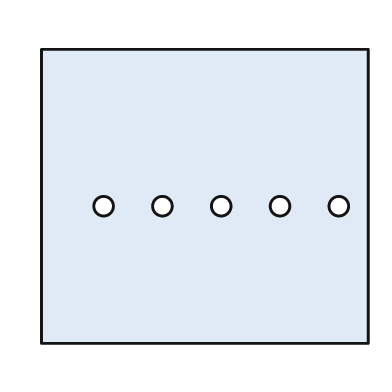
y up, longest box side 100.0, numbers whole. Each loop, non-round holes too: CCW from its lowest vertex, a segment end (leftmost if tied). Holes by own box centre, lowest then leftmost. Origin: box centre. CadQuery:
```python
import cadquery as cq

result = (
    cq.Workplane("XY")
    .moveTo(-50.0, -45.0)
    .lineTo(50.0, -45.0)
    .lineTo(50.0, 45.0)
    .lineTo(-50.0, 45.0)
    .close()
    .moveTo(-31.0, -3.0)
    .circle(3.0)
    .moveTo(-13.0, -3.0)
    .circle(3.0)
    .moveTo(5.0, -3.0)
    .circle(3.0)
    .moveTo(23.0, -3.0)
    .circle(3.0)
    .moveTo(41.0, -3.0)
    .circle(3.0)
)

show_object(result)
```